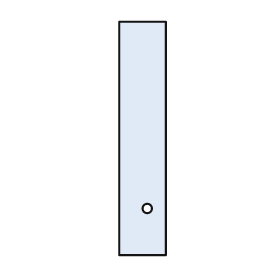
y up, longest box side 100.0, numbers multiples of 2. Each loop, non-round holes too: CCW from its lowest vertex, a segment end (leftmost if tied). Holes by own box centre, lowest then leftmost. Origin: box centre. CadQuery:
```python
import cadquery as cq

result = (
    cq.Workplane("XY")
    .moveTo(-10.0, -50.0)
    .lineTo(10.0, -50.0)
    .lineTo(10.0, 50.0)
    .lineTo(-10.0, 50.0)
    .close()
    .moveTo(2.0, -30.0)
    .circle(2.0)
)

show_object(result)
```